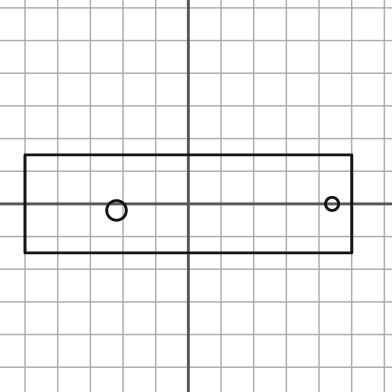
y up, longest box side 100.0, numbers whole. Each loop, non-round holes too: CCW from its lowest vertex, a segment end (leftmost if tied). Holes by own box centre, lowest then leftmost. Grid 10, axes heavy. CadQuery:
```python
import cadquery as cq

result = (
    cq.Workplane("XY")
    .moveTo(-50.0, -15.0)
    .lineTo(50.0, -15.0)
    .lineTo(50.0, 15.0)
    .lineTo(-50.0, 15.0)
    .close()
    .moveTo(-22.0, -2.0)
    .circle(3.0)
    .moveTo(44.0, 0.0)
    .circle(2.0)
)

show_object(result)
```